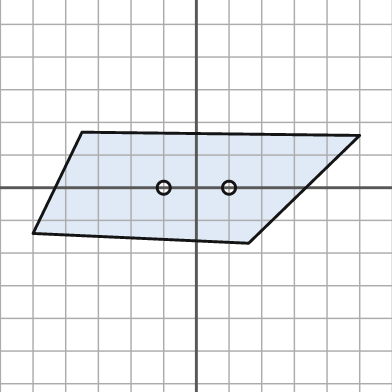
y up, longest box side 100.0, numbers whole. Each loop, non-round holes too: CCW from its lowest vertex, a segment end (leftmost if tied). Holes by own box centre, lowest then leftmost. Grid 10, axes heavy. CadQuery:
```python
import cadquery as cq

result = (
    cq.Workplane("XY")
    .moveTo(16.0, -17.0)
    .lineTo(50.0, 16.0)
    .lineTo(-35.0, 17.0)
    .lineTo(-50.0, -14.0)
    .close()
    .moveTo(-10.0, 0.0)
    .circle(2.0)
    .moveTo(10.0, 0.0)
    .circle(2.0)
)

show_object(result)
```